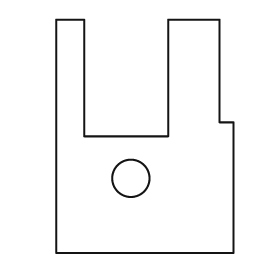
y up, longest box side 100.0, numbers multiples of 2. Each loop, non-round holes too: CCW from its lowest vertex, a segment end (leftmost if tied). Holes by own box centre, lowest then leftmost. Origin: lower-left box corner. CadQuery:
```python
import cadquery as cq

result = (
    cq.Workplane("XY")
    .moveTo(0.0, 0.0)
    .lineTo(76.0, 0.0)
    .lineTo(76.0, 56.0)
    .lineTo(70.0, 56.0)
    .lineTo(70.0, 100.0)
    .lineTo(48.0, 100.0)
    .lineTo(48.0, 50.0)
    .lineTo(12.0, 50.0)
    .lineTo(12.0, 100.0)
    .lineTo(0.0, 100.0)
    .close()
    .moveTo(32.0, 32.0)
    .circle(8.0)
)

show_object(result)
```